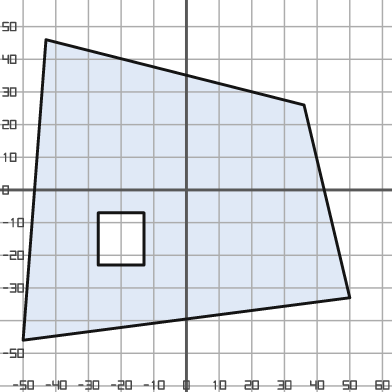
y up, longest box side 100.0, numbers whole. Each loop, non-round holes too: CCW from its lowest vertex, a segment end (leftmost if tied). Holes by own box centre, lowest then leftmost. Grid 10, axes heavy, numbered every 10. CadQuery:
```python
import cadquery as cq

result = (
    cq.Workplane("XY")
    .moveTo(-50.0, -46.0)
    .lineTo(50.0, -33.0)
    .lineTo(36.0, 26.0)
    .lineTo(-43.0, 46.0)
    .close()
    .moveTo(-27.0, -23.0)
    .lineTo(-13.0, -23.0)
    .lineTo(-13.0, -7.0)
    .lineTo(-27.0, -7.0)
    .close()
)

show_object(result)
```